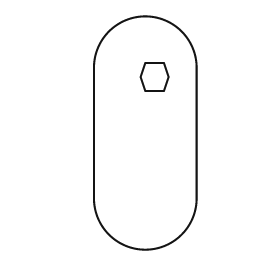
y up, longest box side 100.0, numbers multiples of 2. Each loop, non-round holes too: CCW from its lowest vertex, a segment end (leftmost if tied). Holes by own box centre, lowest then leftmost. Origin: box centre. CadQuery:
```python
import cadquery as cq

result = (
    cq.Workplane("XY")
    .moveTo(-22.0, -28.0)
    .threePointArc((0.0, -50.0), (22.0, -28.0))
    .lineTo(22.0, 28.0)
    .threePointArc((0.0, 50.0), (-22.0, 28.0))
    .close()
    .moveTo(0.0, 18.0)
    .lineTo(8.0, 18.0)
    .lineTo(10.0, 24.0)
    .lineTo(8.0, 30.0)
    .lineTo(0.0, 30.0)
    .lineTo(-2.0, 24.0)
    .close()
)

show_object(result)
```